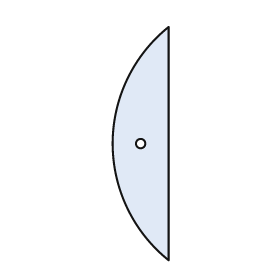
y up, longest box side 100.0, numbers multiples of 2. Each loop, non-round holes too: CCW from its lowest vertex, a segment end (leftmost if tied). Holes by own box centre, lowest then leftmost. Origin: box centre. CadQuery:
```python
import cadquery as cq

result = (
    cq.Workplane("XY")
    .moveTo(12.0, -50.0)
    .lineTo(12.0, 50.0)
    .threePointArc((-12.0, 0.0), (12.0, -50.0))
    .close()
    .moveTo(0.0, 0.0)
    .circle(2.0)
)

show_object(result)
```